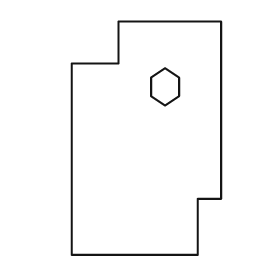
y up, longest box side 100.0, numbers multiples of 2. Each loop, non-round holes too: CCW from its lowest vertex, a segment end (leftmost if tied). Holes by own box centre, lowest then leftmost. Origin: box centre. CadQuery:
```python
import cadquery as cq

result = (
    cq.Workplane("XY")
    .moveTo(-32.0, -50.0)
    .lineTo(22.0, -50.0)
    .lineTo(22.0, -26.0)
    .lineTo(32.0, -26.0)
    .lineTo(32.0, 50.0)
    .lineTo(-12.0, 50.0)
    .lineTo(-12.0, 32.0)
    .lineTo(-32.0, 32.0)
    .close()
    .moveTo(8.0, 14.0)
    .lineTo(14.0, 18.0)
    .lineTo(14.0, 26.0)
    .lineTo(8.0, 30.0)
    .lineTo(2.0, 26.0)
    .lineTo(2.0, 18.0)
    .close()
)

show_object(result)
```